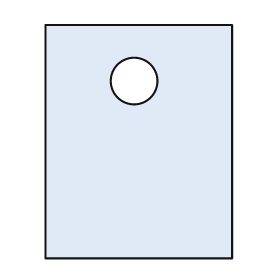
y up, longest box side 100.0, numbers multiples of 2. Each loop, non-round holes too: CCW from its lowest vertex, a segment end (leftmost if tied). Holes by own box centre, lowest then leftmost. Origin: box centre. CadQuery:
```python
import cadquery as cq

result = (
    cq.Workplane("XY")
    .moveTo(-40.0, -50.0)
    .lineTo(40.0, -50.0)
    .lineTo(40.0, 50.0)
    .lineTo(-40.0, 50.0)
    .close()
    .moveTo(-2.0, 26.0)
    .circle(10.0)
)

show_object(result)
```